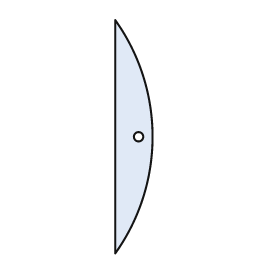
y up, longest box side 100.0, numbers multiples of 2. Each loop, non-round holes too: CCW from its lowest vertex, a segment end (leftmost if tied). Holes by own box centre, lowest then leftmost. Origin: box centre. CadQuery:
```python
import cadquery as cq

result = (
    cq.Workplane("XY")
    .moveTo(-8.0, -50.0)
    .threePointArc((8.0, 0.0), (-8.0, 50.0))
    .close()
    .moveTo(2.0, 0.0)
    .circle(2.0)
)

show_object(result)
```